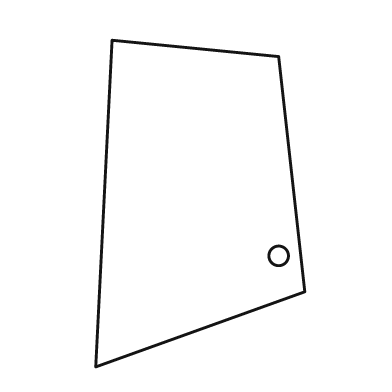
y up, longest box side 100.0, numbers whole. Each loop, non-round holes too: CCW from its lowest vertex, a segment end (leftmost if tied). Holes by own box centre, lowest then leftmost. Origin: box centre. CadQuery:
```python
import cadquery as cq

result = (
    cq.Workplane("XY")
    .moveTo(-32.0, -50.0)
    .lineTo(32.0, -27.0)
    .lineTo(24.0, 45.0)
    .lineTo(-27.0, 50.0)
    .close()
    .moveTo(24.0, -16.0)
    .circle(3.0)
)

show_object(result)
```